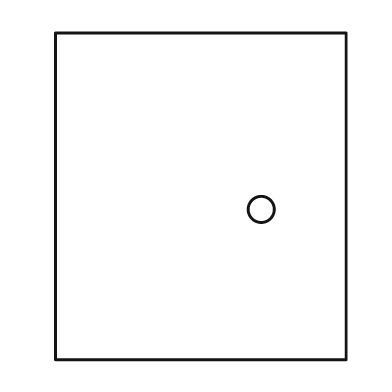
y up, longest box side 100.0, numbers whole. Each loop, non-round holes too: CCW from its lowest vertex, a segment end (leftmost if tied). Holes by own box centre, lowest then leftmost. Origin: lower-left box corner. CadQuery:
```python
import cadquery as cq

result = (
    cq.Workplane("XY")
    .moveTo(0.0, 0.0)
    .lineTo(89.0, 0.0)
    .lineTo(89.0, 100.0)
    .lineTo(0.0, 100.0)
    .close()
    .moveTo(63.0, 46.0)
    .circle(4.0)
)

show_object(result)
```